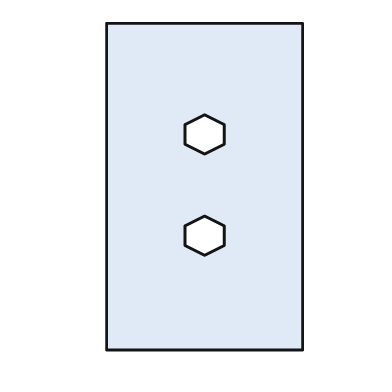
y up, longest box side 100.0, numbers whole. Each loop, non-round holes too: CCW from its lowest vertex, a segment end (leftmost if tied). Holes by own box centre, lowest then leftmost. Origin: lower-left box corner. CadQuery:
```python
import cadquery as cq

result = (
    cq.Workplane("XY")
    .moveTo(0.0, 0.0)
    .lineTo(60.0, 0.0)
    .lineTo(60.0, 100.0)
    .lineTo(0.0, 100.0)
    .close()
    .moveTo(30.0, 29.0)
    .lineTo(36.0, 32.0)
    .lineTo(36.0, 38.0)
    .lineTo(30.0, 41.0)
    .lineTo(24.0, 38.0)
    .lineTo(24.0, 32.0)
    .close()
    .moveTo(30.0, 60.0)
    .lineTo(36.0, 63.0)
    .lineTo(36.0, 69.0)
    .lineTo(30.0, 72.0)
    .lineTo(24.0, 69.0)
    .lineTo(24.0, 63.0)
    .close()
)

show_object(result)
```